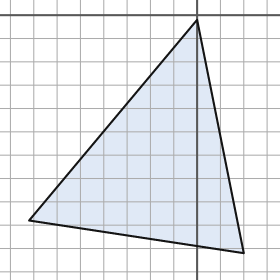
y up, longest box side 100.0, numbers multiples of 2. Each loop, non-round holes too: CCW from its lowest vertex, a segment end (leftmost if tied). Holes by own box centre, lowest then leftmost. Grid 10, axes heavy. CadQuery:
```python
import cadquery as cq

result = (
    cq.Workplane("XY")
    .moveTo(20.0, -102.0)
    .lineTo(0.0, -2.0)
    .lineTo(-72.0, -88.0)
    .close()
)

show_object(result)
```